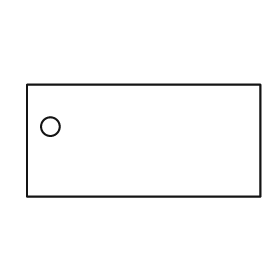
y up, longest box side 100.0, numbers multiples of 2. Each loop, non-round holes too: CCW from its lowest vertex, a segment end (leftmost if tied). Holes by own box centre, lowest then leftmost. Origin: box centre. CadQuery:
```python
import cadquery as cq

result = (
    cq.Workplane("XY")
    .moveTo(-50.0, -24.0)
    .lineTo(50.0, -24.0)
    .lineTo(50.0, 24.0)
    .lineTo(-50.0, 24.0)
    .close()
    .moveTo(-40.0, 6.0)
    .circle(4.0)
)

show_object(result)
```